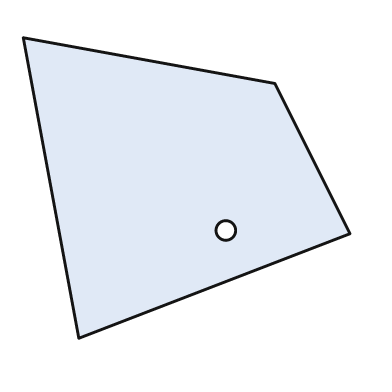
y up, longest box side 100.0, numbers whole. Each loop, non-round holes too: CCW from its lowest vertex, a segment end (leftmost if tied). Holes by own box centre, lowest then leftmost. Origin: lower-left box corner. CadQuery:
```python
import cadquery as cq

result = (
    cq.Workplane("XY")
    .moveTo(17.0, 0.0)
    .lineTo(100.0, 32.0)
    .lineTo(77.0, 78.0)
    .lineTo(0.0, 92.0)
    .close()
    .moveTo(62.0, 33.0)
    .circle(3.0)
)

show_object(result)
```